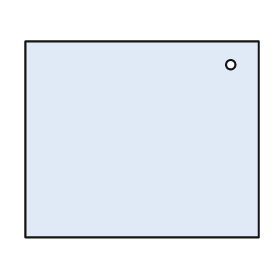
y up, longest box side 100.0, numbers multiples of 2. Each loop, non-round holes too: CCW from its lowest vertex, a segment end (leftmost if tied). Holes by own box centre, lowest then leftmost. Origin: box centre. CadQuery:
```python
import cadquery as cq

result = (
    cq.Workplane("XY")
    .moveTo(-50.0, -42.0)
    .lineTo(50.0, -42.0)
    .lineTo(50.0, 42.0)
    .lineTo(-50.0, 42.0)
    .close()
    .moveTo(38.0, 32.0)
    .circle(2.0)
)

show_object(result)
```